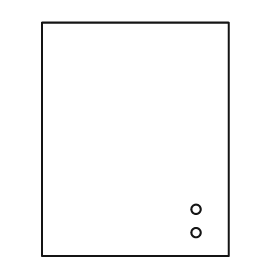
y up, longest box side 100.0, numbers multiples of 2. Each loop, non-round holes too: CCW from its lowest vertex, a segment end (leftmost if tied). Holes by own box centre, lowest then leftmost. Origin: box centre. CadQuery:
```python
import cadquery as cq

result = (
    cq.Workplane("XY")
    .moveTo(-40.0, -50.0)
    .lineTo(40.0, -50.0)
    .lineTo(40.0, 50.0)
    .lineTo(-40.0, 50.0)
    .close()
    .moveTo(26.0, -40.0)
    .circle(2.0)
    .moveTo(26.0, -30.0)
    .circle(2.0)
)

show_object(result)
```